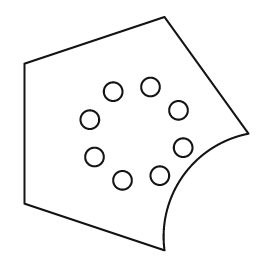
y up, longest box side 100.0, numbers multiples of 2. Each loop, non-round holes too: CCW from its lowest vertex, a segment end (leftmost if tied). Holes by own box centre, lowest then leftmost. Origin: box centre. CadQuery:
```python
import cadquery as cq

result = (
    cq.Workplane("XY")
    .moveTo(12.0, -50.0)
    .threePointArc((20.0, -18.0), (48.0, 0.0))
    .lineTo(12.0, 50.0)
    .lineTo(-48.0, 30.0)
    .lineTo(-48.0, -30.0)
    .close()
    .moveTo(-6.0, -20.0)
    .circle(4.0)
    .moveTo(10.0, -18.0)
    .circle(4.0)
    .moveTo(-18.0, -10.0)
    .circle(4.0)
    .moveTo(20.0, -6.0)
    .circle(4.0)
    .moveTo(-20.0, 6.0)
    .circle(4.0)
    .moveTo(18.0, 10.0)
    .circle(4.0)
    .moveTo(-10.0, 18.0)
    .circle(4.0)
    .moveTo(6.0, 20.0)
    .circle(4.0)
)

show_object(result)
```